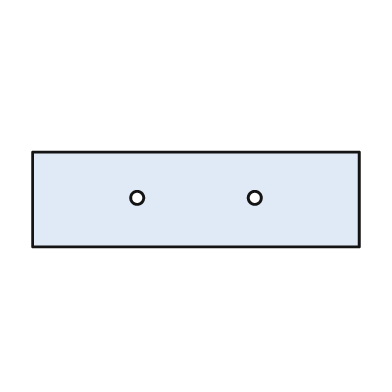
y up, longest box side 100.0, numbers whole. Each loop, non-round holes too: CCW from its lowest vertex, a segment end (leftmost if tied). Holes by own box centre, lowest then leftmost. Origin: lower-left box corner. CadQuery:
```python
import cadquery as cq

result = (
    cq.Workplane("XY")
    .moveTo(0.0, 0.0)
    .lineTo(100.0, 0.0)
    .lineTo(100.0, 29.0)
    .lineTo(0.0, 29.0)
    .close()
    .moveTo(32.0, 15.0)
    .circle(2.0)
    .moveTo(68.0, 15.0)
    .circle(2.0)
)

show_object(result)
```